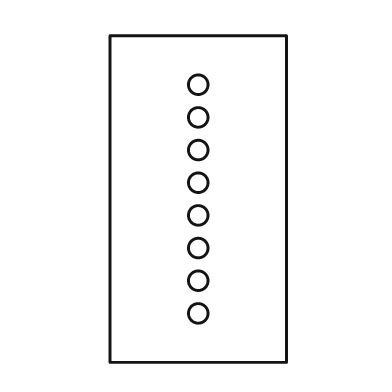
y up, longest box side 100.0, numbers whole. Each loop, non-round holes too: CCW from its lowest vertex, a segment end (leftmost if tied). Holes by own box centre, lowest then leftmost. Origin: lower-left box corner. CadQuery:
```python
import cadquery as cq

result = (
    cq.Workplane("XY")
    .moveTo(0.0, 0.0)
    .lineTo(54.0, 0.0)
    .lineTo(54.0, 100.0)
    .lineTo(0.0, 100.0)
    .close()
    .moveTo(27.0, 15.0)
    .circle(3.0)
    .moveTo(27.0, 25.0)
    .circle(3.0)
    .moveTo(27.0, 35.0)
    .circle(3.0)
    .moveTo(27.0, 45.0)
    .circle(3.0)
    .moveTo(27.0, 55.0)
    .circle(3.0)
    .moveTo(27.0, 65.0)
    .circle(3.0)
    .moveTo(27.0, 75.0)
    .circle(3.0)
    .moveTo(27.0, 85.0)
    .circle(3.0)
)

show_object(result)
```